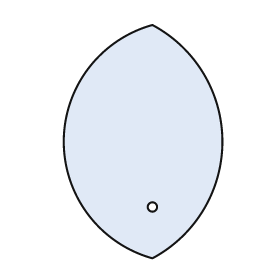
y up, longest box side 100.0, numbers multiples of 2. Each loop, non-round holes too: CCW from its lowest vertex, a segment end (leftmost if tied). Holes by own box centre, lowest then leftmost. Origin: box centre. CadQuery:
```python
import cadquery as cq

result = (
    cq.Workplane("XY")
    .moveTo(4.0, -50.0)
    .threePointArc((34.0, 0.0), (4.0, 50.0))
    .threePointArc((-34.0, 0.0), (4.0, -50.0))
    .close()
    .moveTo(4.0, -28.0)
    .circle(2.0)
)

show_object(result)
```